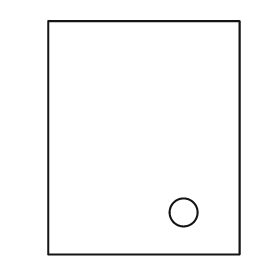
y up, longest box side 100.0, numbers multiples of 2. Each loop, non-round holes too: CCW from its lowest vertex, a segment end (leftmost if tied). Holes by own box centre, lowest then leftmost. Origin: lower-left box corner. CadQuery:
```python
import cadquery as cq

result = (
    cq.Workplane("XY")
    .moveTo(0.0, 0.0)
    .lineTo(82.0, 0.0)
    .lineTo(82.0, 100.0)
    .lineTo(0.0, 100.0)
    .close()
    .moveTo(58.0, 18.0)
    .circle(6.0)
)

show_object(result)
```